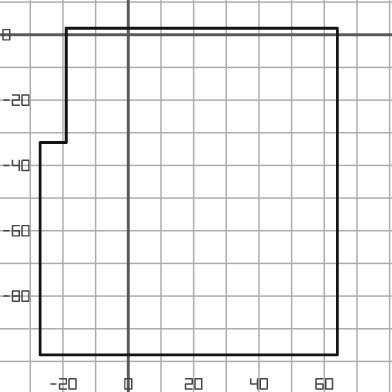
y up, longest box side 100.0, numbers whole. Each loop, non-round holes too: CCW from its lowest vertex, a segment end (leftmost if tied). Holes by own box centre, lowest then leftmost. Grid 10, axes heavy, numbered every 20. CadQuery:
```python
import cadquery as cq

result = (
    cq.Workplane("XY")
    .moveTo(-27.0, -98.0)
    .lineTo(64.0, -98.0)
    .lineTo(64.0, 2.0)
    .lineTo(-19.0, 2.0)
    .lineTo(-19.0, -33.0)
    .lineTo(-27.0, -33.0)
    .close()
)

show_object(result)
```